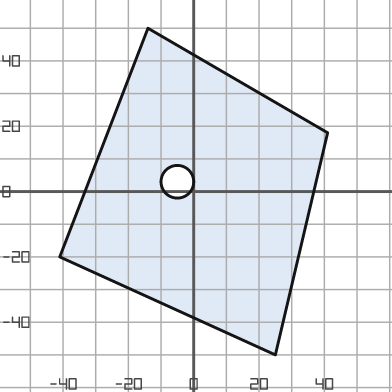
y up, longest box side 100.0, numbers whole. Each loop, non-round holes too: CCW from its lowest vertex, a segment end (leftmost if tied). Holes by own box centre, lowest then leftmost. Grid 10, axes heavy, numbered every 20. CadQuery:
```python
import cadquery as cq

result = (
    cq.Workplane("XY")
    .moveTo(25.0, -50.0)
    .lineTo(41.0, 18.0)
    .lineTo(-14.0, 50.0)
    .lineTo(-41.0, -20.0)
    .close()
    .moveTo(-5.0, 3.0)
    .circle(5.0)
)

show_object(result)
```